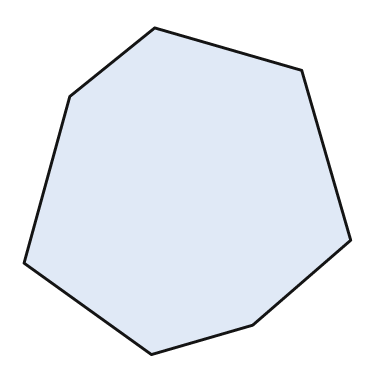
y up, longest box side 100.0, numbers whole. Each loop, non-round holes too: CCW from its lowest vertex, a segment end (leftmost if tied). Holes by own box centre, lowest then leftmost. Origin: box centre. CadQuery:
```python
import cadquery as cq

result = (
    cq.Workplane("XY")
    .moveTo(-11.0, -50.0)
    .lineTo(20.0, -41.0)
    .lineTo(50.0, -15.0)
    .lineTo(35.0, 37.0)
    .lineTo(-10.0, 50.0)
    .lineTo(-36.0, 29.0)
    .lineTo(-50.0, -22.0)
    .close()
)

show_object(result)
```